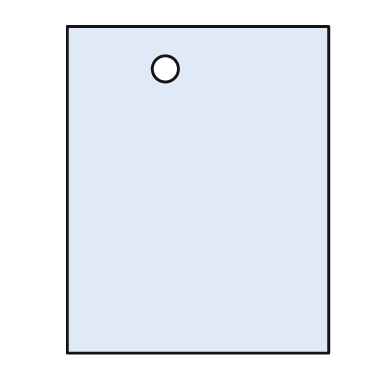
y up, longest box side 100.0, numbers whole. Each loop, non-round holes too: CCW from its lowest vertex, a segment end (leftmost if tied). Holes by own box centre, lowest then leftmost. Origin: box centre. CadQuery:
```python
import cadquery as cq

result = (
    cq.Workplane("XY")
    .moveTo(-40.0, -50.0)
    .lineTo(40.0, -50.0)
    .lineTo(40.0, 50.0)
    .lineTo(-40.0, 50.0)
    .close()
    .moveTo(-10.0, 37.0)
    .circle(4.0)
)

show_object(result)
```